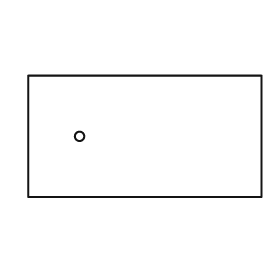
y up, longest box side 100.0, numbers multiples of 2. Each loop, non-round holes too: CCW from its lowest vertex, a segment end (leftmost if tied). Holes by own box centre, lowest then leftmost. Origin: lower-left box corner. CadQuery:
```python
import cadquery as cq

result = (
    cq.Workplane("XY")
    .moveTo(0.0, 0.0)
    .lineTo(100.0, 0.0)
    .lineTo(100.0, 52.0)
    .lineTo(0.0, 52.0)
    .close()
    .moveTo(22.0, 26.0)
    .circle(2.0)
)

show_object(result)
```